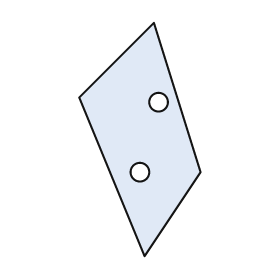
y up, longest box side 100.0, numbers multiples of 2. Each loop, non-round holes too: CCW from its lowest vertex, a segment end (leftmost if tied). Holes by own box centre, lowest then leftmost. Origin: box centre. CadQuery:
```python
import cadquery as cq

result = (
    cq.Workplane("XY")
    .moveTo(2.0, -50.0)
    .lineTo(26.0, -14.0)
    .lineTo(6.0, 50.0)
    .lineTo(-26.0, 18.0)
    .close()
    .moveTo(0.0, -14.0)
    .circle(4.0)
    .moveTo(8.0, 16.0)
    .circle(4.0)
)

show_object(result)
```